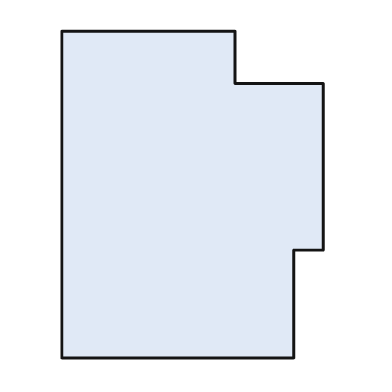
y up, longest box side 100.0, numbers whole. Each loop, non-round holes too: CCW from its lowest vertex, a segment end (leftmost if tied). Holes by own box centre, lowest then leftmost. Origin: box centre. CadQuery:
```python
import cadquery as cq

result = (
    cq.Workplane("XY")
    .moveTo(-40.0, -50.0)
    .lineTo(31.0, -50.0)
    .lineTo(31.0, -17.0)
    .lineTo(40.0, -17.0)
    .lineTo(40.0, 34.0)
    .lineTo(13.0, 34.0)
    .lineTo(13.0, 50.0)
    .lineTo(-40.0, 50.0)
    .close()
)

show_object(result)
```